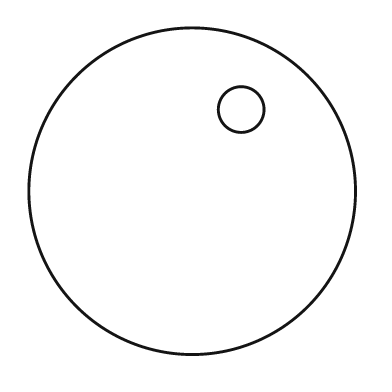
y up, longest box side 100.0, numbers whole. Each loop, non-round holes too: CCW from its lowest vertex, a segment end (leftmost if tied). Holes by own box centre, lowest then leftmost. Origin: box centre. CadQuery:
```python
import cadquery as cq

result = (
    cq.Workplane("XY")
    .moveTo(0.0, 0.0)
    .circle(50.0)
    .moveTo(15.0, 25.0)
    .circle(7.0)
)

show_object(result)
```